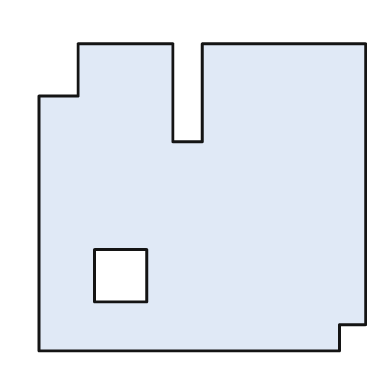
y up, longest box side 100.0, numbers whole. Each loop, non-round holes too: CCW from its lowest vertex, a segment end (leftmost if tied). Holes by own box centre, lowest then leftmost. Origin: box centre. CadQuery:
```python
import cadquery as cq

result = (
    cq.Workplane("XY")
    .moveTo(-50.0, -47.0)
    .lineTo(42.0, -47.0)
    .lineTo(42.0, -39.0)
    .lineTo(50.0, -39.0)
    .lineTo(50.0, 47.0)
    .lineTo(0.0, 47.0)
    .lineTo(0.0, 17.0)
    .lineTo(-9.0, 17.0)
    .lineTo(-9.0, 47.0)
    .lineTo(-38.0, 47.0)
    .lineTo(-38.0, 31.0)
    .lineTo(-50.0, 31.0)
    .close()
    .moveTo(-33.0, -32.0)
    .lineTo(-17.0, -32.0)
    .lineTo(-17.0, -16.0)
    .lineTo(-33.0, -16.0)
    .close()
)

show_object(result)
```